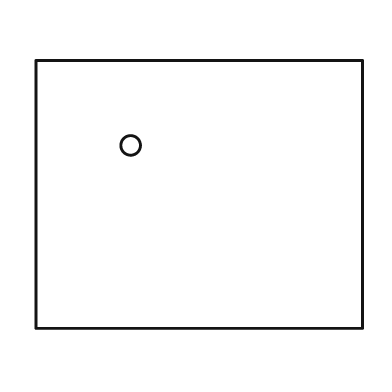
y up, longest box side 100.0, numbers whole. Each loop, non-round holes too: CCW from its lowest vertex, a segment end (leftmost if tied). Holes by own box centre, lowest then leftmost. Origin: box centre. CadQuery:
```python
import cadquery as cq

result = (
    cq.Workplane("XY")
    .moveTo(-50.0, -41.0)
    .lineTo(50.0, -41.0)
    .lineTo(50.0, 41.0)
    .lineTo(-50.0, 41.0)
    .close()
    .moveTo(-21.0, 15.0)
    .circle(3.0)
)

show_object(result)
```